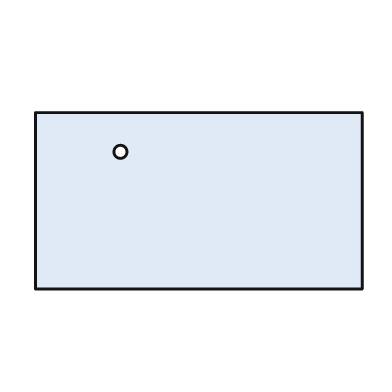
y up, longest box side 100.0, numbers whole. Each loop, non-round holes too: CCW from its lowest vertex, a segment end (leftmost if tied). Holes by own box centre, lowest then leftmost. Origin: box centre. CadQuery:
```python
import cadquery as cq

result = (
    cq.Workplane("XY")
    .moveTo(-50.0, -27.0)
    .lineTo(50.0, -27.0)
    .lineTo(50.0, 27.0)
    .lineTo(-50.0, 27.0)
    .close()
    .moveTo(-24.0, 15.0)
    .circle(2.0)
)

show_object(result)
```